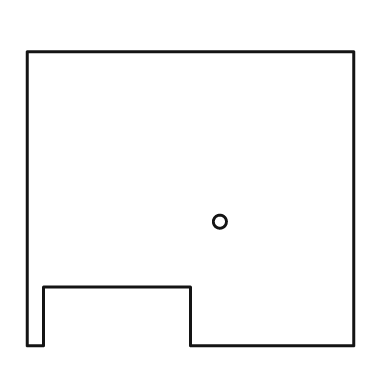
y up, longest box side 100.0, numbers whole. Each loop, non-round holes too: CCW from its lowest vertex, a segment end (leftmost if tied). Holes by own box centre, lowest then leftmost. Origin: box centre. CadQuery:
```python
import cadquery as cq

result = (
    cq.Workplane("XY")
    .moveTo(-50.0, -45.0)
    .lineTo(-45.0, -45.0)
    .lineTo(-45.0, -27.0)
    .lineTo(0.0, -27.0)
    .lineTo(0.0, -45.0)
    .lineTo(50.0, -45.0)
    .lineTo(50.0, 45.0)
    .lineTo(-50.0, 45.0)
    .close()
    .moveTo(9.0, -7.0)
    .circle(2.0)
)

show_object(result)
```